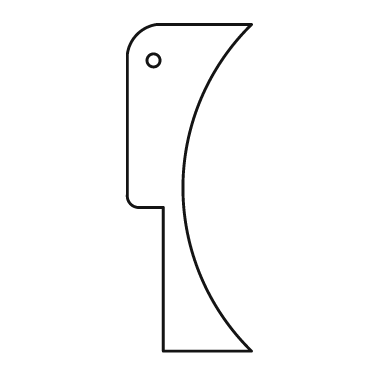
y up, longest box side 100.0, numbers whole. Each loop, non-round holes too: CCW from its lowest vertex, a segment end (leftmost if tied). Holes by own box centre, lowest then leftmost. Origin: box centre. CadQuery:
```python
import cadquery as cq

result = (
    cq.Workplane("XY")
    .moveTo(-8.0, -50.0)
    .lineTo(19.0, -50.0)
    .threePointArc((-2.0, 0.0), (19.0, 50.0))
    .lineTo(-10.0, 50.0)
    .threePointArc((-16.0, 47.0), (-19.0, 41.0))
    .lineTo(-19.0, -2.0)
    .threePointArc((-18.0, -5.0), (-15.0, -6.0))
    .lineTo(-8.0, -6.0)
    .close()
    .moveTo(-11.0, 39.0)
    .circle(2.0)
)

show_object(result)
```